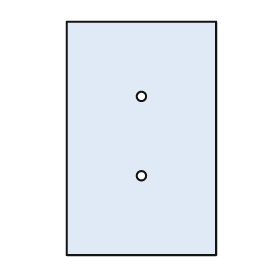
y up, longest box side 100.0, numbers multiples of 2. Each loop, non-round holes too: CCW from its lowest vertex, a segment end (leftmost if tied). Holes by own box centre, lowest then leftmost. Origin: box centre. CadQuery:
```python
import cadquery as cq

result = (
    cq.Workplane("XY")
    .moveTo(-32.0, -50.0)
    .lineTo(32.0, -50.0)
    .lineTo(32.0, 50.0)
    .lineTo(-32.0, 50.0)
    .close()
    .moveTo(0.0, -16.0)
    .circle(2.0)
    .moveTo(0.0, 18.0)
    .circle(2.0)
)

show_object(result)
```